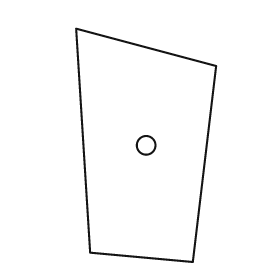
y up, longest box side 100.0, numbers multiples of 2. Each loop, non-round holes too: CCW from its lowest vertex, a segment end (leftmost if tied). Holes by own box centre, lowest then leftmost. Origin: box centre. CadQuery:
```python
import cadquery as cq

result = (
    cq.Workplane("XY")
    .moveTo(20.0, -50.0)
    .lineTo(30.0, 34.0)
    .lineTo(-30.0, 50.0)
    .lineTo(-24.0, -46.0)
    .close()
    .moveTo(0.0, 0.0)
    .circle(4.0)
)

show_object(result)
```